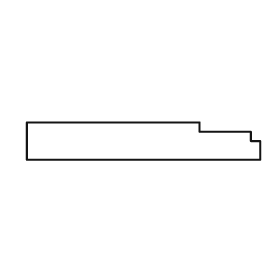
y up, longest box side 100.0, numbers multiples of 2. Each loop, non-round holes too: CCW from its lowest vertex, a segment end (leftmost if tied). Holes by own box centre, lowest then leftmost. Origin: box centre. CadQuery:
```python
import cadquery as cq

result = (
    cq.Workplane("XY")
    .moveTo(-50.0, -8.0)
    .lineTo(50.0, -8.0)
    .lineTo(50.0, 0.0)
    .lineTo(46.0, 0.0)
    .lineTo(46.0, 4.0)
    .lineTo(24.0, 4.0)
    .lineTo(24.0, 8.0)
    .lineTo(-50.0, 8.0)
    .close()
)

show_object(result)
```